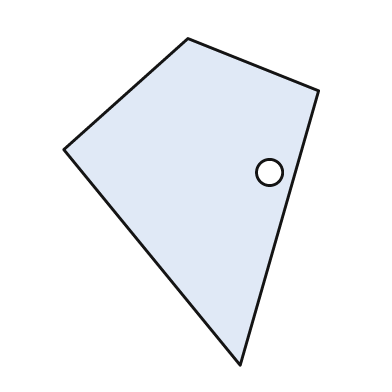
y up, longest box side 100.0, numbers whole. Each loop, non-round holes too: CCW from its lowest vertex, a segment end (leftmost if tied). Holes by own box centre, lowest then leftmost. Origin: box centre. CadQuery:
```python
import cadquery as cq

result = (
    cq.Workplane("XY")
    .moveTo(15.0, -50.0)
    .lineTo(39.0, 34.0)
    .lineTo(-1.0, 50.0)
    .lineTo(-39.0, 16.0)
    .close()
    .moveTo(24.0, 9.0)
    .circle(4.0)
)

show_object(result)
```